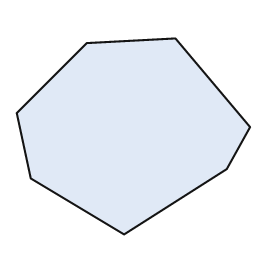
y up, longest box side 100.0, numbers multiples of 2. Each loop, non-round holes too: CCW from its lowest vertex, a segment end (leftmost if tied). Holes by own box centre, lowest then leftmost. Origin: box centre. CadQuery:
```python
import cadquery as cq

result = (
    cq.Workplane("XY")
    .moveTo(-4.0, -42.0)
    .lineTo(40.0, -14.0)
    .lineTo(50.0, 4.0)
    .lineTo(18.0, 42.0)
    .lineTo(-20.0, 40.0)
    .lineTo(-50.0, 10.0)
    .lineTo(-44.0, -18.0)
    .close()
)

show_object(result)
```